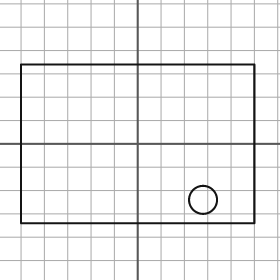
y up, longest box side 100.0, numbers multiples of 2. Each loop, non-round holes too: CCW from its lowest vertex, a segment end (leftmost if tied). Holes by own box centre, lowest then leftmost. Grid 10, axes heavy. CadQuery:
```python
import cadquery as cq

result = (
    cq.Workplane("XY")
    .moveTo(-50.0, -34.0)
    .lineTo(50.0, -34.0)
    .lineTo(50.0, 34.0)
    .lineTo(-50.0, 34.0)
    .close()
    .moveTo(28.0, -24.0)
    .circle(6.0)
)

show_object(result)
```